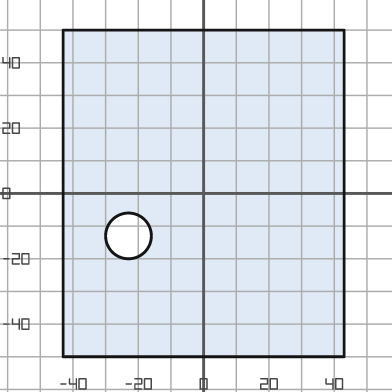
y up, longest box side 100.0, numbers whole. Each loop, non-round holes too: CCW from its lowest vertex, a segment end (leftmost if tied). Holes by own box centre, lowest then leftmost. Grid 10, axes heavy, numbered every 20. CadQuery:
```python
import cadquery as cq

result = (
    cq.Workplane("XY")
    .moveTo(-43.0, -50.0)
    .lineTo(43.0, -50.0)
    .lineTo(43.0, 50.0)
    .lineTo(-43.0, 50.0)
    .close()
    .moveTo(-23.0, -13.0)
    .circle(7.0)
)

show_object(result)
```